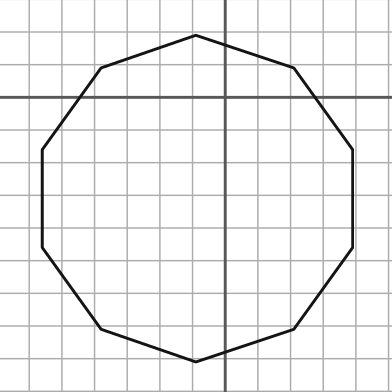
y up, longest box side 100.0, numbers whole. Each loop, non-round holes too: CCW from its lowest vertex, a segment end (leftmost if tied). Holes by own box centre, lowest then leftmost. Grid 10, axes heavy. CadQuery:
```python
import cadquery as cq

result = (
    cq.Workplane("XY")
    .moveTo(-9.0, -81.0)
    .lineTo(21.0, -71.0)
    .lineTo(39.0, -46.0)
    .lineTo(39.0, -16.0)
    .lineTo(21.0, 9.0)
    .lineTo(-9.0, 19.0)
    .lineTo(-38.0, 9.0)
    .lineTo(-56.0, -16.0)
    .lineTo(-56.0, -46.0)
    .lineTo(-38.0, -71.0)
    .close()
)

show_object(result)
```